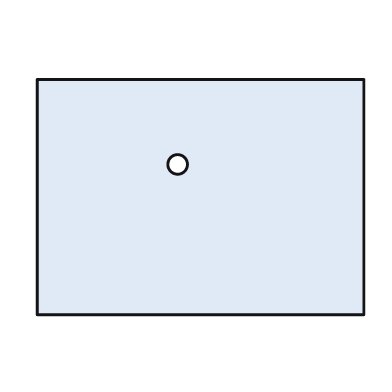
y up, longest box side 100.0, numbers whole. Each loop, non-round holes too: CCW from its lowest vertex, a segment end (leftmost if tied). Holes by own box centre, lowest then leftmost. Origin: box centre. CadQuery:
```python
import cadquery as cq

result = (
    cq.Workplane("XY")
    .moveTo(-50.0, -36.0)
    .lineTo(50.0, -36.0)
    .lineTo(50.0, 36.0)
    .lineTo(-50.0, 36.0)
    .close()
    .moveTo(-7.0, 10.0)
    .circle(3.0)
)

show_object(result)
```